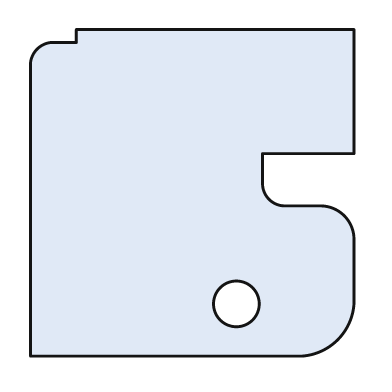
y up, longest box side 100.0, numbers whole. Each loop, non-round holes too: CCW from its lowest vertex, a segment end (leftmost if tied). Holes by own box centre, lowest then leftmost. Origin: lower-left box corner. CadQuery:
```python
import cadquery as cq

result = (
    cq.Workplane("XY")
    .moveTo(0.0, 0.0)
    .lineTo(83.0, 0.0)
    .threePointArc((94.0, 5.0), (99.0, 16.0))
    .lineTo(99.0, 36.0)
    .threePointArc((96.0, 43.0), (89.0, 46.0))
    .lineTo(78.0, 46.0)
    .threePointArc((73.0, 48.0), (71.0, 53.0))
    .lineTo(71.0, 62.0)
    .lineTo(99.0, 62.0)
    .lineTo(99.0, 100.0)
    .lineTo(14.0, 100.0)
    .lineTo(14.0, 96.0)
    .lineTo(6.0, 96.0)
    .threePointArc((2.0, 94.0), (0.0, 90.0))
    .close()
    .moveTo(63.0, 16.0)
    .circle(7.0)
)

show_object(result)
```